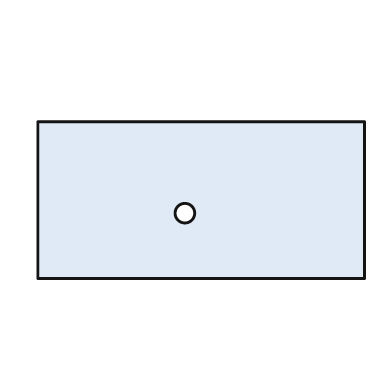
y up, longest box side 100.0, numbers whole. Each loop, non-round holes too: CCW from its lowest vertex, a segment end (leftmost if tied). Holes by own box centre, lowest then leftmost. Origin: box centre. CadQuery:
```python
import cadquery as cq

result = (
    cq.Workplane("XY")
    .moveTo(-50.0, -24.0)
    .lineTo(50.0, -24.0)
    .lineTo(50.0, 24.0)
    .lineTo(-50.0, 24.0)
    .close()
    .moveTo(-5.0, -4.0)
    .circle(3.0)
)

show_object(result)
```